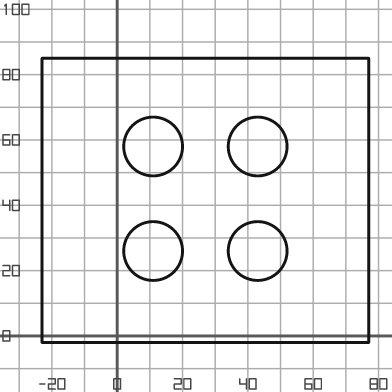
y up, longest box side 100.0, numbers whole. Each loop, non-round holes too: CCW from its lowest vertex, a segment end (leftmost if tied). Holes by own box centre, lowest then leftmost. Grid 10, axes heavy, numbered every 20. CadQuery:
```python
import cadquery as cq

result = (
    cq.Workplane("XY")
    .moveTo(-23.0, -2.0)
    .lineTo(77.0, -2.0)
    .lineTo(77.0, 85.0)
    .lineTo(-23.0, 85.0)
    .close()
    .moveTo(11.0, 26.0)
    .circle(9.0)
    .moveTo(43.0, 26.0)
    .circle(9.0)
    .moveTo(11.0, 58.0)
    .circle(9.0)
    .moveTo(43.0, 58.0)
    .circle(9.0)
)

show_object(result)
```